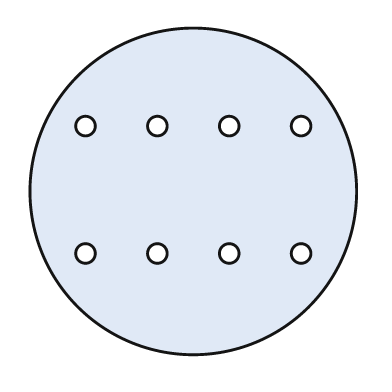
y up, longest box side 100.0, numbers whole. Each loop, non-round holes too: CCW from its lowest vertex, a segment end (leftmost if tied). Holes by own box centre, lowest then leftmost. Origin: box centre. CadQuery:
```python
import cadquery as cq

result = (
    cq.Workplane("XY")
    .moveTo(0.0, 0.0)
    .circle(50.0)
    .moveTo(-33.0, -19.0)
    .circle(3.0)
    .moveTo(-11.0, -19.0)
    .circle(3.0)
    .moveTo(11.0, -19.0)
    .circle(3.0)
    .moveTo(33.0, -19.0)
    .circle(3.0)
    .moveTo(-33.0, 20.0)
    .circle(3.0)
    .moveTo(-11.0, 20.0)
    .circle(3.0)
    .moveTo(11.0, 20.0)
    .circle(3.0)
    .moveTo(33.0, 20.0)
    .circle(3.0)
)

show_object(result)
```